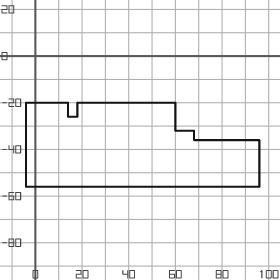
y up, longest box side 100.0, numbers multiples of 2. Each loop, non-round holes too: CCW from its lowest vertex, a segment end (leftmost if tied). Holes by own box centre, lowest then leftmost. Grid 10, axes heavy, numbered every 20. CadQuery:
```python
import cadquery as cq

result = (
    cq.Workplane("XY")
    .moveTo(-4.0, -56.0)
    .lineTo(96.0, -56.0)
    .lineTo(96.0, -36.0)
    .lineTo(68.0, -36.0)
    .lineTo(68.0, -32.0)
    .lineTo(60.0, -32.0)
    .lineTo(60.0, -20.0)
    .lineTo(18.0, -20.0)
    .lineTo(18.0, -26.0)
    .lineTo(14.0, -26.0)
    .lineTo(14.0, -20.0)
    .lineTo(-4.0, -20.0)
    .close()
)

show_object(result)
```